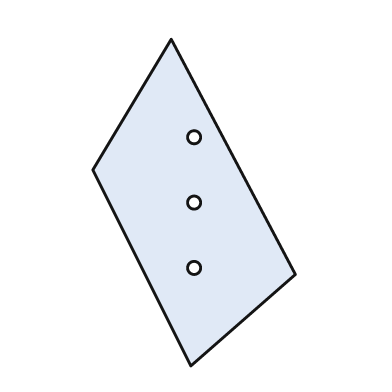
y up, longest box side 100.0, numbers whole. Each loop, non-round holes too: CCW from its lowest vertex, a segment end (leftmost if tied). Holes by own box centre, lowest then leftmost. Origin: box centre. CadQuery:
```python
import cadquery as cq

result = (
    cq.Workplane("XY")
    .moveTo(-1.0, -50.0)
    .lineTo(31.0, -22.0)
    .lineTo(-7.0, 50.0)
    .lineTo(-31.0, 10.0)
    .close()
    .moveTo(0.0, -20.0)
    .circle(2.0)
    .moveTo(0.0, 0.0)
    .circle(2.0)
    .moveTo(0.0, 20.0)
    .circle(2.0)
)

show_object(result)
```